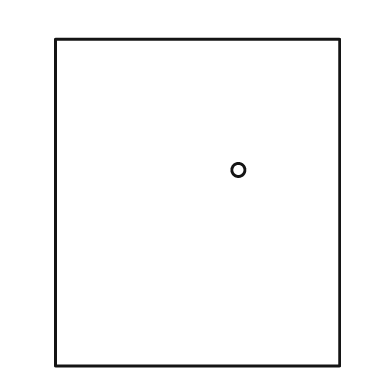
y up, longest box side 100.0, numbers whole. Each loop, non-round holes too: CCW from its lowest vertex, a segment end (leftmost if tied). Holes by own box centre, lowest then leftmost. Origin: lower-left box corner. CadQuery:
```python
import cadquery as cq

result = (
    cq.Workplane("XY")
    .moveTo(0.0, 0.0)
    .lineTo(87.0, 0.0)
    .lineTo(87.0, 100.0)
    .lineTo(0.0, 100.0)
    .close()
    .moveTo(56.0, 60.0)
    .circle(2.0)
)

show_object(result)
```